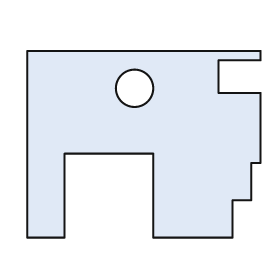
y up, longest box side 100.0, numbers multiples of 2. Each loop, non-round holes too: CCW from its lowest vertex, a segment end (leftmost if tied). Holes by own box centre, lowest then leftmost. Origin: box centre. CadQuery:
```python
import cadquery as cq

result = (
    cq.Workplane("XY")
    .moveTo(-50.0, -40.0)
    .lineTo(-34.0, -40.0)
    .lineTo(-34.0, -4.0)
    .lineTo(4.0, -4.0)
    .lineTo(4.0, -40.0)
    .lineTo(38.0, -40.0)
    .lineTo(38.0, -24.0)
    .lineTo(46.0, -24.0)
    .lineTo(46.0, -8.0)
    .lineTo(50.0, -8.0)
    .lineTo(50.0, 22.0)
    .lineTo(32.0, 22.0)
    .lineTo(32.0, 36.0)
    .lineTo(50.0, 36.0)
    .lineTo(50.0, 40.0)
    .lineTo(-50.0, 40.0)
    .close()
    .moveTo(-4.0, 24.0)
    .circle(8.0)
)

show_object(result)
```